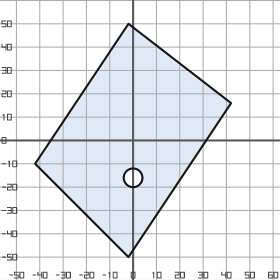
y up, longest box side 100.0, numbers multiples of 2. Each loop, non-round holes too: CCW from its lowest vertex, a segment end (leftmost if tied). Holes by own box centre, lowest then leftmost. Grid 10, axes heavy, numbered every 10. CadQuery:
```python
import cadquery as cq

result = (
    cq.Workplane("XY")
    .moveTo(-2.0, -50.0)
    .lineTo(42.0, 16.0)
    .lineTo(-2.0, 50.0)
    .lineTo(-42.0, -10.0)
    .close()
    .moveTo(0.0, -16.0)
    .circle(4.0)
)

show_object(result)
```